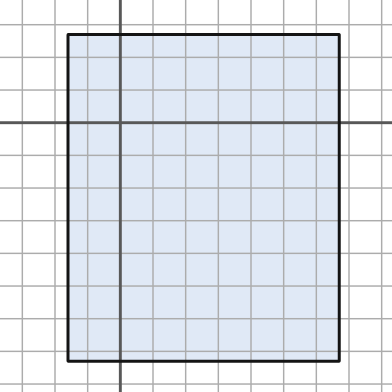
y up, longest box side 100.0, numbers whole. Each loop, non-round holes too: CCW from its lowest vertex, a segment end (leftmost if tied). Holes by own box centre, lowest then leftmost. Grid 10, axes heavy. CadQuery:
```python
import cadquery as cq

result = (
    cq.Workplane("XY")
    .moveTo(-16.0, -73.0)
    .lineTo(67.0, -73.0)
    .lineTo(67.0, 27.0)
    .lineTo(-16.0, 27.0)
    .close()
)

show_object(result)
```